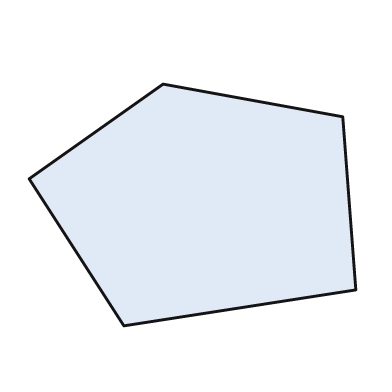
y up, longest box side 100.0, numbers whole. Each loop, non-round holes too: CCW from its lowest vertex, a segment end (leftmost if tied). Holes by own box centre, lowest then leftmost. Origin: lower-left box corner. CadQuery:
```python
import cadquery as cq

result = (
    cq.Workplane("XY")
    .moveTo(29.0, 0.0)
    .lineTo(100.0, 11.0)
    .lineTo(96.0, 64.0)
    .lineTo(41.0, 74.0)
    .lineTo(0.0, 45.0)
    .close()
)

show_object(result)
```